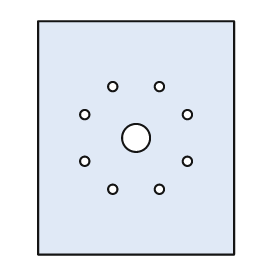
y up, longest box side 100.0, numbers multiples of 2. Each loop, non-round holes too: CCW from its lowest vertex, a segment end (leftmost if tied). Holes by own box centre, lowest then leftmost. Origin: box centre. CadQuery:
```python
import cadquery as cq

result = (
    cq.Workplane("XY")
    .moveTo(-42.0, -50.0)
    .lineTo(42.0, -50.0)
    .lineTo(42.0, 50.0)
    .lineTo(-42.0, 50.0)
    .close()
    .moveTo(-10.0, -22.0)
    .circle(2.0)
    .moveTo(10.0, -22.0)
    .circle(2.0)
    .moveTo(-22.0, -10.0)
    .circle(2.0)
    .moveTo(22.0, -10.0)
    .circle(2.0)
    .moveTo(0.0, 0.0)
    .circle(6.0)
    .moveTo(-22.0, 10.0)
    .circle(2.0)
    .moveTo(22.0, 10.0)
    .circle(2.0)
    .moveTo(-10.0, 22.0)
    .circle(2.0)
    .moveTo(10.0, 22.0)
    .circle(2.0)
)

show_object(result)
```